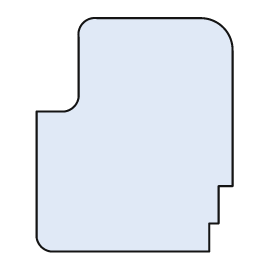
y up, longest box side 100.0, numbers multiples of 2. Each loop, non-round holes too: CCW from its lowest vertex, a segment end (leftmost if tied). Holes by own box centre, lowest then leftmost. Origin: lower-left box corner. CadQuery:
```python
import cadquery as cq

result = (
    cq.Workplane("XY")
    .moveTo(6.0, 0.0)
    .lineTo(74.0, 0.0)
    .lineTo(74.0, 12.0)
    .lineTo(78.0, 12.0)
    .lineTo(78.0, 28.0)
    .lineTo(84.0, 28.0)
    .lineTo(84.0, 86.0)
    .threePointArc((80.0, 96.0), (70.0, 100.0))
    .lineTo(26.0, 100.0)
    .threePointArc((20.0, 98.0), (18.0, 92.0))
    .lineTo(18.0, 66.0)
    .threePointArc((16.0, 62.0), (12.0, 60.0))
    .lineTo(0.0, 60.0)
    .lineTo(0.0, 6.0)
    .threePointArc((2.0, 2.0), (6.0, 0.0))
    .close()
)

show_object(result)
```